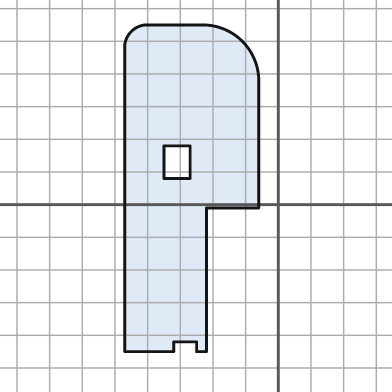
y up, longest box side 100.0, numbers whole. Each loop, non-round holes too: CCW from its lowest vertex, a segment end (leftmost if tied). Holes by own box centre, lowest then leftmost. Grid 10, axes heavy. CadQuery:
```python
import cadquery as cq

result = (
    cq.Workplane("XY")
    .moveTo(-47.0, -45.0)
    .lineTo(-32.0, -45.0)
    .lineTo(-32.0, -42.0)
    .lineTo(-25.0, -42.0)
    .lineTo(-25.0, -45.0)
    .lineTo(-22.0, -45.0)
    .lineTo(-22.0, -1.0)
    .lineTo(-6.0, -1.0)
    .lineTo(-6.0, 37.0)
    .threePointArc((-11.0, 50.0), (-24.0, 55.0))
    .lineTo(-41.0, 55.0)
    .threePointArc((-45.0, 53.0), (-47.0, 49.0))
    .close()
    .moveTo(-35.0, 8.0)
    .lineTo(-27.0, 8.0)
    .lineTo(-27.0, 18.0)
    .lineTo(-35.0, 18.0)
    .close()
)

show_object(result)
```